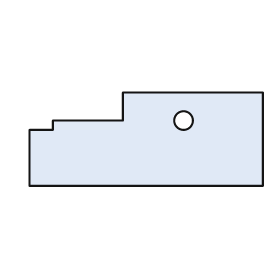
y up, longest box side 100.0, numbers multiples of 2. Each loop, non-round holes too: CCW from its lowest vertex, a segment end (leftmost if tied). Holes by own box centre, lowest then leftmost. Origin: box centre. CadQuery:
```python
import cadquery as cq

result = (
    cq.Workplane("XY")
    .moveTo(-50.0, -20.0)
    .lineTo(50.0, -20.0)
    .lineTo(50.0, 20.0)
    .lineTo(-10.0, 20.0)
    .lineTo(-10.0, 8.0)
    .lineTo(-40.0, 8.0)
    .lineTo(-40.0, 4.0)
    .lineTo(-50.0, 4.0)
    .close()
    .moveTo(16.0, 8.0)
    .circle(4.0)
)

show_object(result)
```